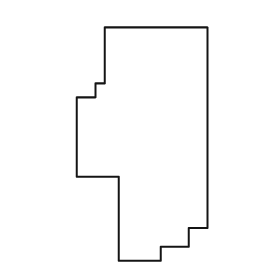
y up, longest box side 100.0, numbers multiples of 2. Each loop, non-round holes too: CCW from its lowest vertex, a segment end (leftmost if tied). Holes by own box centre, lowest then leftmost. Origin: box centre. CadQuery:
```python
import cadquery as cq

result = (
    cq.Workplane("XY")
    .moveTo(-10.0, -50.0)
    .lineTo(8.0, -50.0)
    .lineTo(8.0, -44.0)
    .lineTo(20.0, -44.0)
    .lineTo(20.0, -36.0)
    .lineTo(28.0, -36.0)
    .lineTo(28.0, 50.0)
    .lineTo(-16.0, 50.0)
    .lineTo(-16.0, 26.0)
    .lineTo(-20.0, 26.0)
    .lineTo(-20.0, 20.0)
    .lineTo(-28.0, 20.0)
    .lineTo(-28.0, -14.0)
    .lineTo(-10.0, -14.0)
    .close()
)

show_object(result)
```